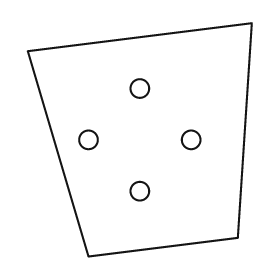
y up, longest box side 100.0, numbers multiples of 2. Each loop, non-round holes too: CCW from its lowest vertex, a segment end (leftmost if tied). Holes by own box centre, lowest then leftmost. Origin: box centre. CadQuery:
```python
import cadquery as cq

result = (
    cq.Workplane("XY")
    .moveTo(-22.0, -50.0)
    .lineTo(42.0, -42.0)
    .lineTo(48.0, 50.0)
    .lineTo(-48.0, 38.0)
    .close()
    .moveTo(0.0, -22.0)
    .circle(4.0)
    .moveTo(-22.0, 0.0)
    .circle(4.0)
    .moveTo(22.0, 0.0)
    .circle(4.0)
    .moveTo(0.0, 22.0)
    .circle(4.0)
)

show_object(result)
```